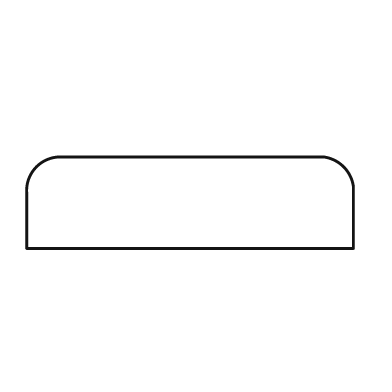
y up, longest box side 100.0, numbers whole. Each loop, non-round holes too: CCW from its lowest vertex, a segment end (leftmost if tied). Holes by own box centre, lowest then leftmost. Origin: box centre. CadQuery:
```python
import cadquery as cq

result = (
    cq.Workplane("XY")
    .moveTo(-50.0, -14.0)
    .lineTo(50.0, -14.0)
    .lineTo(50.0, 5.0)
    .threePointArc((47.0, 11.0), (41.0, 14.0))
    .lineTo(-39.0, 14.0)
    .threePointArc((-47.0, 11.0), (-50.0, 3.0))
    .close()
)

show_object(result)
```